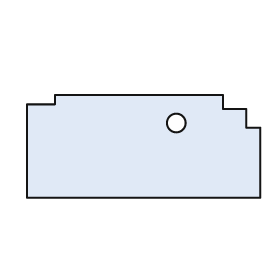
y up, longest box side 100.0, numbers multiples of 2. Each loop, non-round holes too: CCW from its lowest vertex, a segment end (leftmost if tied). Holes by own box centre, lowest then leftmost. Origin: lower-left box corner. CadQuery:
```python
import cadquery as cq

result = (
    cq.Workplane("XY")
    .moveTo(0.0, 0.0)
    .lineTo(100.0, 0.0)
    .lineTo(100.0, 30.0)
    .lineTo(94.0, 30.0)
    .lineTo(94.0, 38.0)
    .lineTo(84.0, 38.0)
    .lineTo(84.0, 44.0)
    .lineTo(12.0, 44.0)
    .lineTo(12.0, 40.0)
    .lineTo(0.0, 40.0)
    .close()
    .moveTo(64.0, 32.0)
    .circle(4.0)
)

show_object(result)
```